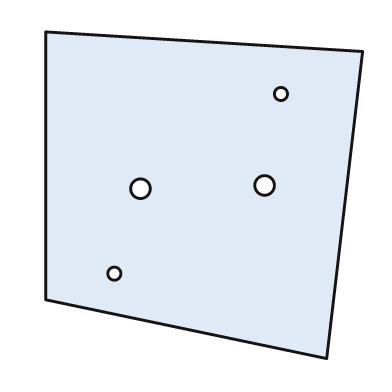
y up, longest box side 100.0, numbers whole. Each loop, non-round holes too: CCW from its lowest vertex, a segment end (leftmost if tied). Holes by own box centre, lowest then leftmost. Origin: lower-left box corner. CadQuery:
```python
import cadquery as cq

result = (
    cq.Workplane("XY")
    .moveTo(86.0, 0.0)
    .lineTo(97.0, 94.0)
    .lineTo(0.0, 100.0)
    .lineTo(0.0, 18.0)
    .close()
    .moveTo(21.0, 26.0)
    .circle(2.0)
    .moveTo(29.0, 52.0)
    .circle(3.0)
    .moveTo(67.0, 53.0)
    .circle(3.0)
    .moveTo(72.0, 81.0)
    .circle(2.0)
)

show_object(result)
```